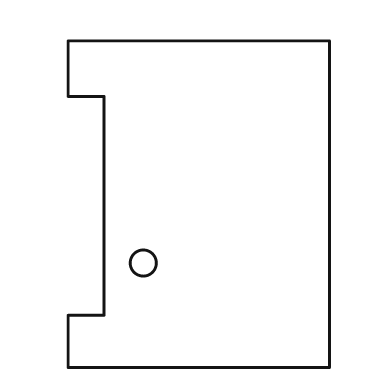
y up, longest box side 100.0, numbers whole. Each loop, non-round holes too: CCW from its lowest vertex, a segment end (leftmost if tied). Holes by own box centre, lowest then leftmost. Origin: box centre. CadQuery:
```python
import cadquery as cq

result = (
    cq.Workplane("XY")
    .moveTo(-40.0, -50.0)
    .lineTo(40.0, -50.0)
    .lineTo(40.0, 50.0)
    .lineTo(-40.0, 50.0)
    .lineTo(-40.0, 33.0)
    .lineTo(-29.0, 33.0)
    .lineTo(-29.0, -34.0)
    .lineTo(-40.0, -34.0)
    .close()
    .moveTo(-17.0, -18.0)
    .circle(4.0)
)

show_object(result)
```